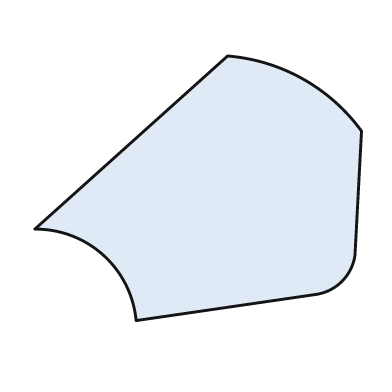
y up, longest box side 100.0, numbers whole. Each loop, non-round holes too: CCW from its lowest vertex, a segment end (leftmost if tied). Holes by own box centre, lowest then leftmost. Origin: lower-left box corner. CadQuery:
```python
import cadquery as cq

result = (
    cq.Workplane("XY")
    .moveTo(31.0, 0.0)
    .lineTo(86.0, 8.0)
    .threePointArc((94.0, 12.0), (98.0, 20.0))
    .lineTo(100.0, 58.0)
    .threePointArc((82.0, 74.0), (59.0, 81.0))
    .lineTo(0.0, 28.0)
    .threePointArc((21.0, 20.0), (31.0, 0.0))
    .close()
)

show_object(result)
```